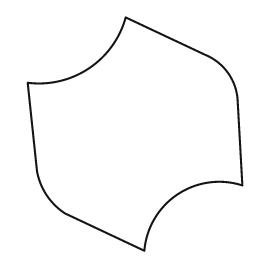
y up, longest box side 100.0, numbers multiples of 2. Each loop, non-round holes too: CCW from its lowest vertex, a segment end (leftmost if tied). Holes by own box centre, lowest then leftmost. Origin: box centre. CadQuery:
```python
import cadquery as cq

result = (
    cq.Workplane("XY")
    .moveTo(4.0, -50.0)
    .threePointArc((18.0, -26.0), (46.0, -22.0))
    .lineTo(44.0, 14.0)
    .threePointArc((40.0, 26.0), (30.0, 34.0))
    .lineTo(-4.0, 50.0)
    .threePointArc((-20.0, 28.0), (-46.0, 22.0))
    .lineTo(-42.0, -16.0)
    .threePointArc((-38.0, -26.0), (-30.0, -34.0))
    .close()
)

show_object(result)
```